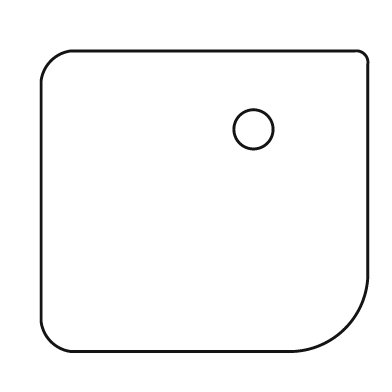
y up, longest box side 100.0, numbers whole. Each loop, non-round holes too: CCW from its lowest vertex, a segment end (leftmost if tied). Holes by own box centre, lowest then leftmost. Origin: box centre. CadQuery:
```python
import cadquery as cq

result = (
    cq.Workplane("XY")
    .moveTo(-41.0, -46.0)
    .lineTo(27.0, -46.0)
    .threePointArc((43.0, -39.0), (50.0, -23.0))
    .lineTo(50.0, 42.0)
    .threePointArc((49.0, 45.0), (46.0, 46.0))
    .lineTo(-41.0, 46.0)
    .threePointArc((-47.0, 43.0), (-50.0, 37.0))
    .lineTo(-50.0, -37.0)
    .threePointArc((-47.0, -43.0), (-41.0, -46.0))
    .close()
    .moveTo(15.0, 22.0)
    .circle(6.0)
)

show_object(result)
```